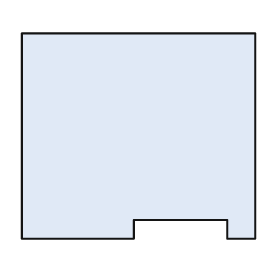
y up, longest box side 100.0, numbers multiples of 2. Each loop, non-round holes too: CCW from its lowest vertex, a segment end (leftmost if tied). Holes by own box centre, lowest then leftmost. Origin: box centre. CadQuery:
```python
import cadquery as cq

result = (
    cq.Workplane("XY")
    .moveTo(-50.0, -44.0)
    .lineTo(-2.0, -44.0)
    .lineTo(-2.0, -36.0)
    .lineTo(38.0, -36.0)
    .lineTo(38.0, -44.0)
    .lineTo(50.0, -44.0)
    .lineTo(50.0, 44.0)
    .lineTo(-50.0, 44.0)
    .close()
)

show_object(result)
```